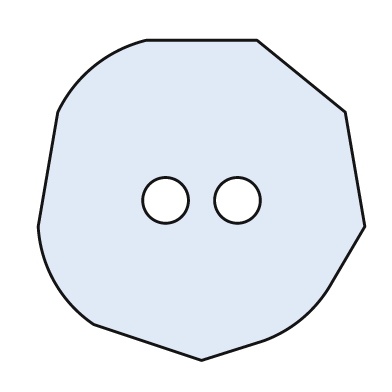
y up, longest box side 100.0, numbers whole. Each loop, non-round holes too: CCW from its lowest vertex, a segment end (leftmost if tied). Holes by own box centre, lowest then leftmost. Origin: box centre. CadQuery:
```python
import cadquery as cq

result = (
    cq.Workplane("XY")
    .moveTo(0.0, -49.0)
    .lineTo(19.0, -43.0)
    .threePointArc((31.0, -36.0), (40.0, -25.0))
    .lineTo(50.0, -8.0)
    .lineTo(44.0, 27.0)
    .lineTo(17.0, 49.0)
    .lineTo(-17.0, 49.0)
    .threePointArc((-33.0, 41.0), (-44.0, 27.0))
    .lineTo(-50.0, -8.0)
    .threePointArc((-45.0, -25.0), (-33.0, -38.0))
    .close()
    .moveTo(-11.0, 0.0)
    .circle(7.0)
    .moveTo(11.0, 0.0)
    .circle(7.0)
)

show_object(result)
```